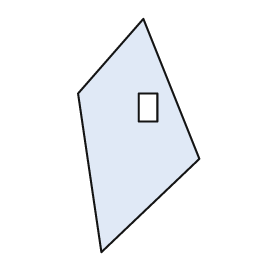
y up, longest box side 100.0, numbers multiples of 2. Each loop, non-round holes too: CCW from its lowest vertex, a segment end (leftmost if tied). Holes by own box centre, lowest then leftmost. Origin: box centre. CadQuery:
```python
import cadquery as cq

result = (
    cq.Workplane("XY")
    .moveTo(-16.0, -50.0)
    .lineTo(26.0, -10.0)
    .lineTo(2.0, 50.0)
    .lineTo(-26.0, 18.0)
    .close()
    .moveTo(0.0, 6.0)
    .lineTo(8.0, 6.0)
    .lineTo(8.0, 18.0)
    .lineTo(0.0, 18.0)
    .close()
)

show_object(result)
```